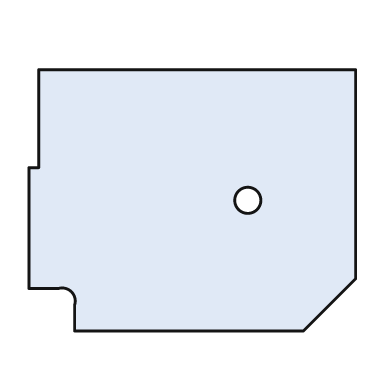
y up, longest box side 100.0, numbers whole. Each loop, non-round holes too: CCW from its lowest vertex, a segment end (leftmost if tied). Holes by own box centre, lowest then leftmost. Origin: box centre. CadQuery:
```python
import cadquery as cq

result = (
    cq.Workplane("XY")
    .moveTo(-36.0, -40.0)
    .lineTo(34.0, -40.0)
    .lineTo(50.0, -24.0)
    .lineTo(50.0, 40.0)
    .lineTo(-47.0, 40.0)
    .lineTo(-47.0, 10.0)
    .lineTo(-50.0, 10.0)
    .lineTo(-50.0, -27.0)
    .lineTo(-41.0, -27.0)
    .threePointArc((-37.0, -28.0), (-36.0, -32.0))
    .close()
    .moveTo(17.0, 0.0)
    .circle(4.0)
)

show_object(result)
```